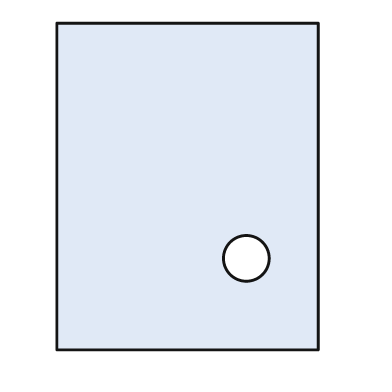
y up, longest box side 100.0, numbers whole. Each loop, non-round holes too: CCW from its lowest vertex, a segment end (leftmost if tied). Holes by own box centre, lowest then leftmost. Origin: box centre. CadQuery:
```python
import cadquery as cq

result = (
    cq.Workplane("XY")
    .moveTo(-40.0, -50.0)
    .lineTo(40.0, -50.0)
    .lineTo(40.0, 50.0)
    .lineTo(-40.0, 50.0)
    .close()
    .moveTo(18.0, -22.0)
    .circle(7.0)
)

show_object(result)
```